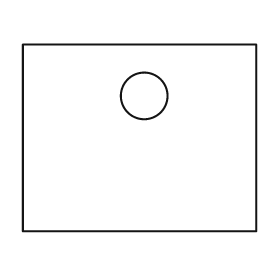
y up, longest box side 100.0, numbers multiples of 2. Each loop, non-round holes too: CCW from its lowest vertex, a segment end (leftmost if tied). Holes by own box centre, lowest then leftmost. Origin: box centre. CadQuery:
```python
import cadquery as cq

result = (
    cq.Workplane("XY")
    .moveTo(-50.0, -40.0)
    .lineTo(50.0, -40.0)
    .lineTo(50.0, 40.0)
    .lineTo(-50.0, 40.0)
    .close()
    .moveTo(2.0, 18.0)
    .circle(10.0)
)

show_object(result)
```